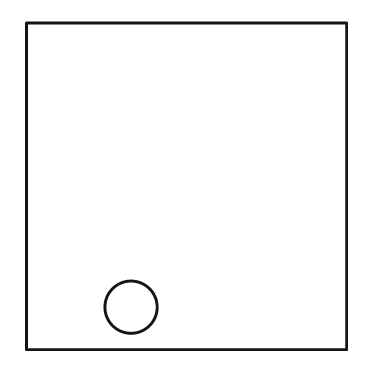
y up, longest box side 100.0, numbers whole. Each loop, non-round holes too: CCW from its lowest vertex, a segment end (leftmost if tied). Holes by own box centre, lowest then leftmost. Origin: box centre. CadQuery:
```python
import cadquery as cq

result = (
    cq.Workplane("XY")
    .moveTo(-49.0, -50.0)
    .lineTo(49.0, -50.0)
    .lineTo(49.0, 50.0)
    .lineTo(-49.0, 50.0)
    .close()
    .moveTo(-17.0, -37.0)
    .circle(8.0)
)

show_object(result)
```